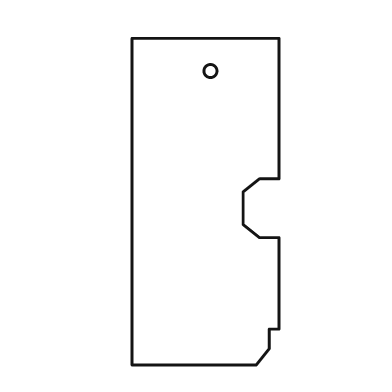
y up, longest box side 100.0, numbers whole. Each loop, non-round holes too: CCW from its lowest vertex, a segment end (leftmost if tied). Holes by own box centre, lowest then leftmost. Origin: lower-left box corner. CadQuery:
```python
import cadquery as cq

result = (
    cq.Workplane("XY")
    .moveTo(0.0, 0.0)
    .lineTo(38.0, 0.0)
    .lineTo(42.0, 5.0)
    .lineTo(42.0, 11.0)
    .lineTo(45.0, 11.0)
    .lineTo(45.0, 39.0)
    .lineTo(39.0, 39.0)
    .lineTo(34.0, 43.0)
    .lineTo(34.0, 53.0)
    .lineTo(39.0, 57.0)
    .lineTo(45.0, 57.0)
    .lineTo(45.0, 100.0)
    .lineTo(0.0, 100.0)
    .close()
    .moveTo(24.0, 90.0)
    .circle(2.0)
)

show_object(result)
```